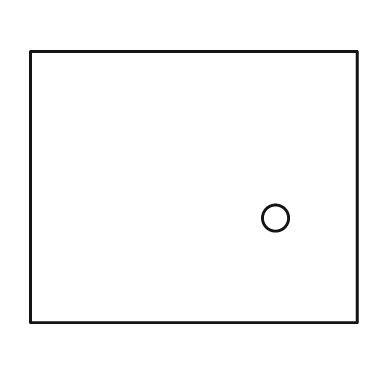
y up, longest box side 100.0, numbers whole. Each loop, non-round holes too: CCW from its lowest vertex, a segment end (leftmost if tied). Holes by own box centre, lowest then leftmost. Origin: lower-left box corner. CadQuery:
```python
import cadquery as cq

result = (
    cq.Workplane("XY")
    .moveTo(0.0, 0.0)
    .lineTo(100.0, 0.0)
    .lineTo(100.0, 83.0)
    .lineTo(0.0, 83.0)
    .close()
    .moveTo(75.0, 32.0)
    .circle(4.0)
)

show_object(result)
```